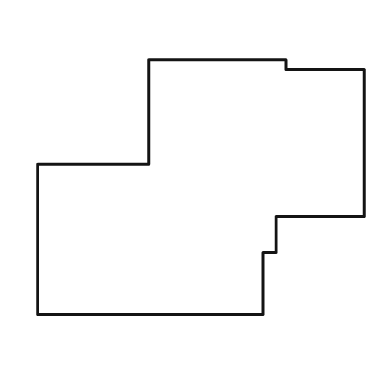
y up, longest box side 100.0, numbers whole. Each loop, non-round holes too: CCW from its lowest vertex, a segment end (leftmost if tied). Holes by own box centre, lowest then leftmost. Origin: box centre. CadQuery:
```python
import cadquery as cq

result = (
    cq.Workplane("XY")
    .moveTo(-50.0, -39.0)
    .lineTo(19.0, -39.0)
    .lineTo(19.0, -20.0)
    .lineTo(23.0, -20.0)
    .lineTo(23.0, -9.0)
    .lineTo(50.0, -9.0)
    .lineTo(50.0, 36.0)
    .lineTo(26.0, 36.0)
    .lineTo(26.0, 39.0)
    .lineTo(-16.0, 39.0)
    .lineTo(-16.0, 7.0)
    .lineTo(-50.0, 7.0)
    .close()
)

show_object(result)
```